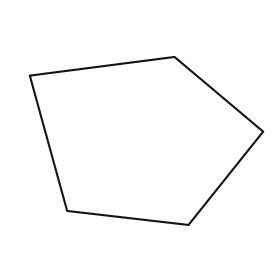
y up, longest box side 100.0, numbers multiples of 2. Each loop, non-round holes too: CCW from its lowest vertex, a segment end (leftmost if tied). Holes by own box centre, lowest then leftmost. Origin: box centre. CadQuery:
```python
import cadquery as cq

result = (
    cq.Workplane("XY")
    .moveTo(18.0, -36.0)
    .lineTo(50.0, 4.0)
    .lineTo(12.0, 36.0)
    .lineTo(-50.0, 28.0)
    .lineTo(-34.0, -30.0)
    .close()
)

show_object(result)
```